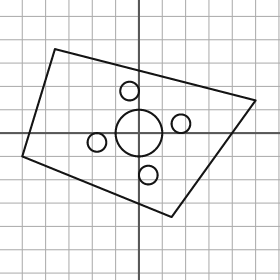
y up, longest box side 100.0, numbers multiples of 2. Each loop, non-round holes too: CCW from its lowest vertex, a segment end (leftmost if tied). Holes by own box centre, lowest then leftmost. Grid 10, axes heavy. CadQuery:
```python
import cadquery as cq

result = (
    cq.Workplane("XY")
    .moveTo(14.0, -36.0)
    .lineTo(50.0, 14.0)
    .lineTo(-36.0, 36.0)
    .lineTo(-50.0, -10.0)
    .close()
    .moveTo(4.0, -18.0)
    .circle(4.0)
    .moveTo(-18.0, -4.0)
    .circle(4.0)
    .moveTo(0.0, 0.0)
    .circle(10.0)
    .moveTo(18.0, 4.0)
    .circle(4.0)
    .moveTo(-4.0, 18.0)
    .circle(4.0)
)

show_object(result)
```